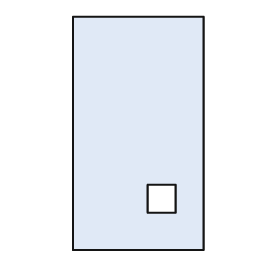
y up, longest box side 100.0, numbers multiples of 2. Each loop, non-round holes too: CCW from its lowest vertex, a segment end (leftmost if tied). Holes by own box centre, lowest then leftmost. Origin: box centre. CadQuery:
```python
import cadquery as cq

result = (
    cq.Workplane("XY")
    .moveTo(-28.0, -50.0)
    .lineTo(28.0, -50.0)
    .lineTo(28.0, 50.0)
    .lineTo(-28.0, 50.0)
    .close()
    .moveTo(4.0, -34.0)
    .lineTo(16.0, -34.0)
    .lineTo(16.0, -22.0)
    .lineTo(4.0, -22.0)
    .close()
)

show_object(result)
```